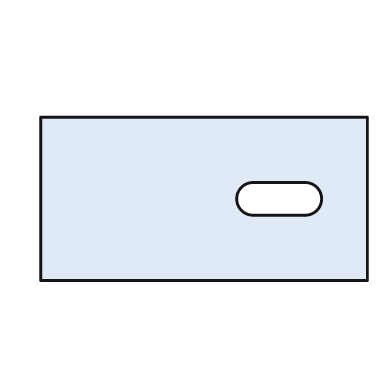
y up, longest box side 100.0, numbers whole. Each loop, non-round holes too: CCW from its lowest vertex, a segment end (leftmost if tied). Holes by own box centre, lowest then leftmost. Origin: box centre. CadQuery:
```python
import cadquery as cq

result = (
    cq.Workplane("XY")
    .moveTo(-50.0, -25.0)
    .lineTo(50.0, -25.0)
    .lineTo(50.0, 25.0)
    .lineTo(-50.0, 25.0)
    .close()
    .moveTo(15.0, -5.0)
    .lineTo(31.0, -5.0)
    .threePointArc((36.0, 0.0), (31.0, 5.0))
    .lineTo(15.0, 5.0)
    .threePointArc((10.0, 0.0), (15.0, -5.0))
    .close()
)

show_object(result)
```